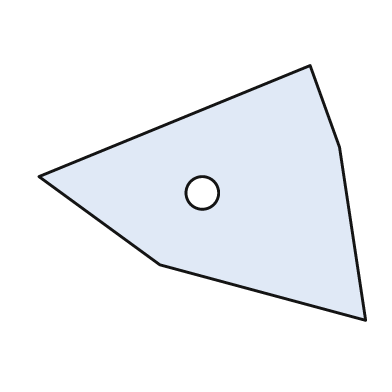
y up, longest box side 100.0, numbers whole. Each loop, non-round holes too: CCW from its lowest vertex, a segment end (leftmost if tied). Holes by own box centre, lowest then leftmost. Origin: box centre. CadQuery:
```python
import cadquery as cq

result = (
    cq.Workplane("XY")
    .moveTo(50.0, -39.0)
    .lineTo(42.0, 14.0)
    .lineTo(33.0, 39.0)
    .lineTo(-50.0, 5.0)
    .lineTo(-13.0, -22.0)
    .close()
    .moveTo(0.0, 0.0)
    .circle(5.0)
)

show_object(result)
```